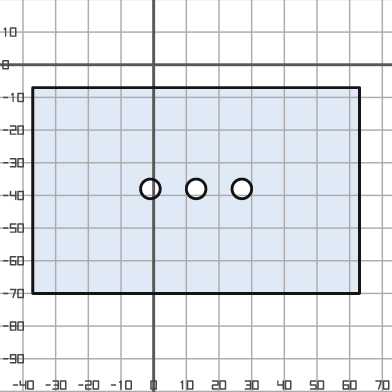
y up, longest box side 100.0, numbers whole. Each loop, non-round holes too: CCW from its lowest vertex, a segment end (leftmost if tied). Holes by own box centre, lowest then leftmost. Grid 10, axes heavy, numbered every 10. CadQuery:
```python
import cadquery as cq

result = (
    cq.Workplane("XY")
    .moveTo(-37.0, -70.0)
    .lineTo(63.0, -70.0)
    .lineTo(63.0, -7.0)
    .lineTo(-37.0, -7.0)
    .close()
    .moveTo(-1.0, -38.0)
    .circle(3.0)
    .moveTo(13.0, -38.0)
    .circle(3.0)
    .moveTo(27.0, -38.0)
    .circle(3.0)
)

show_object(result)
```